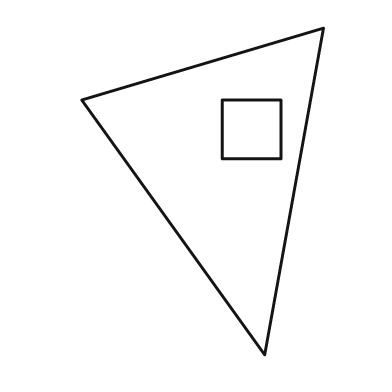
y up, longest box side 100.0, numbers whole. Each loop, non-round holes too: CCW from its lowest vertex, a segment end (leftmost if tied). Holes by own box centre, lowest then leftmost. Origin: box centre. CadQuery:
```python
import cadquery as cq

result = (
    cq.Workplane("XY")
    .moveTo(19.0, -50.0)
    .lineTo(37.0, 50.0)
    .lineTo(-37.0, 28.0)
    .close()
    .moveTo(6.0, 10.0)
    .lineTo(24.0, 10.0)
    .lineTo(24.0, 28.0)
    .lineTo(6.0, 28.0)
    .close()
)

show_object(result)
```